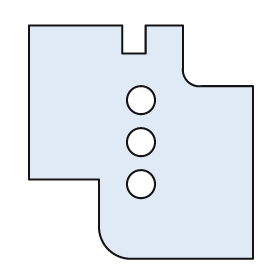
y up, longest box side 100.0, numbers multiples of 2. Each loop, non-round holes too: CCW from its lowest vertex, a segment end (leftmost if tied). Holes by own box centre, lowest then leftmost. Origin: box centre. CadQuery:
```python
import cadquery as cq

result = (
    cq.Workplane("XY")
    .moveTo(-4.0, -50.0)
    .lineTo(48.0, -50.0)
    .lineTo(48.0, 24.0)
    .lineTo(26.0, 24.0)
    .threePointArc((20.0, 26.0), (18.0, 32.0))
    .lineTo(18.0, 50.0)
    .lineTo(2.0, 50.0)
    .lineTo(2.0, 38.0)
    .lineTo(-8.0, 38.0)
    .lineTo(-8.0, 50.0)
    .lineTo(-48.0, 50.0)
    .lineTo(-48.0, -16.0)
    .lineTo(-18.0, -16.0)
    .lineTo(-18.0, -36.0)
    .threePointArc((-14.0, -46.0), (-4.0, -50.0))
    .close()
    .moveTo(0.0, -18.0)
    .circle(6.0)
    .moveTo(0.0, 0.0)
    .circle(6.0)
    .moveTo(0.0, 18.0)
    .circle(6.0)
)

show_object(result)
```